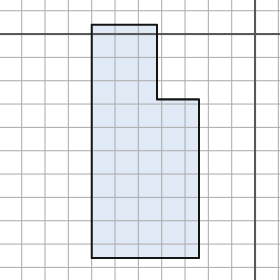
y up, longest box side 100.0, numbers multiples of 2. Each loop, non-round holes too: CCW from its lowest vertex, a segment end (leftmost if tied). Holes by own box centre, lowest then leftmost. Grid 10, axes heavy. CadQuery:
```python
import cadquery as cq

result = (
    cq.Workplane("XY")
    .moveTo(-70.0, -96.0)
    .lineTo(-24.0, -96.0)
    .lineTo(-24.0, -28.0)
    .lineTo(-42.0, -28.0)
    .lineTo(-42.0, 4.0)
    .lineTo(-70.0, 4.0)
    .close()
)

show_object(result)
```